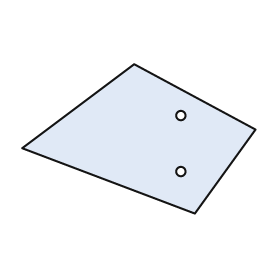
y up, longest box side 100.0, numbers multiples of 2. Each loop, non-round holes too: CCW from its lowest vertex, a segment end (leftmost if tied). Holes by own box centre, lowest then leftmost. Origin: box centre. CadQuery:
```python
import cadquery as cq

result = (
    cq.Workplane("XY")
    .moveTo(24.0, -32.0)
    .lineTo(50.0, 4.0)
    .lineTo(-2.0, 32.0)
    .lineTo(-50.0, -4.0)
    .close()
    .moveTo(18.0, -14.0)
    .circle(2.0)
    .moveTo(18.0, 10.0)
    .circle(2.0)
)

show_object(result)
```